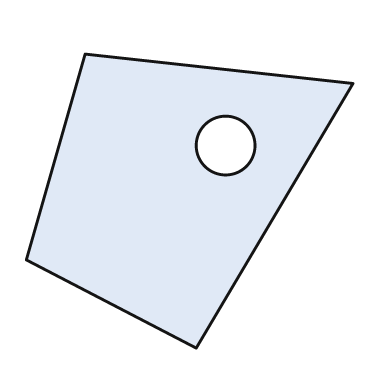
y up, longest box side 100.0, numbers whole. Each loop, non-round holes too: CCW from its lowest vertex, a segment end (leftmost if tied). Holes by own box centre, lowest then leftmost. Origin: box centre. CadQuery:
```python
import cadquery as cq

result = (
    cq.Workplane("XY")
    .moveTo(2.0, -45.0)
    .lineTo(50.0, 36.0)
    .lineTo(-32.0, 45.0)
    .lineTo(-50.0, -18.0)
    .close()
    .moveTo(11.0, 17.0)
    .circle(9.0)
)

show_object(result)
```